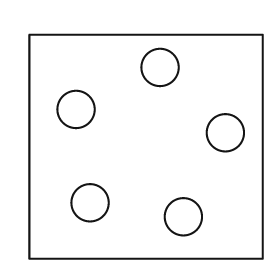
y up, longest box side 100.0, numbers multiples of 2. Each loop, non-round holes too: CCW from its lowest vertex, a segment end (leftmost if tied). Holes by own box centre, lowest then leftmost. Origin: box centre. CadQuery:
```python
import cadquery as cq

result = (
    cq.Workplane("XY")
    .moveTo(-50.0, -48.0)
    .lineTo(50.0, -48.0)
    .lineTo(50.0, 48.0)
    .lineTo(-50.0, 48.0)
    .close()
    .moveTo(16.0, -30.0)
    .circle(8.0)
    .moveTo(-24.0, -24.0)
    .circle(8.0)
    .moveTo(34.0, 6.0)
    .circle(8.0)
    .moveTo(-30.0, 16.0)
    .circle(8.0)
    .moveTo(6.0, 34.0)
    .circle(8.0)
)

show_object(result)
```